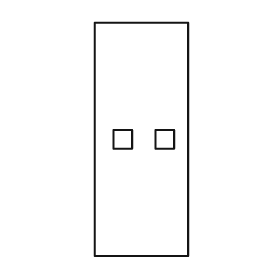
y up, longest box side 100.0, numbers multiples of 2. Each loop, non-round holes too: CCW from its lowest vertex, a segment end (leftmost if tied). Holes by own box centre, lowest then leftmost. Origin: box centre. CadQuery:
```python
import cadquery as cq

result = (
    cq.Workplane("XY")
    .moveTo(-20.0, -50.0)
    .lineTo(20.0, -50.0)
    .lineTo(20.0, 50.0)
    .lineTo(-20.0, 50.0)
    .close()
    .moveTo(-12.0, -4.0)
    .lineTo(-4.0, -4.0)
    .lineTo(-4.0, 4.0)
    .lineTo(-12.0, 4.0)
    .close()
    .moveTo(6.0, -4.0)
    .lineTo(14.0, -4.0)
    .lineTo(14.0, 4.0)
    .lineTo(6.0, 4.0)
    .close()
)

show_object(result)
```